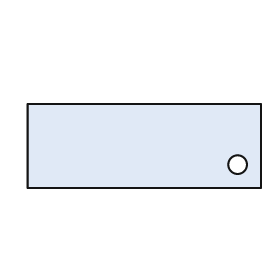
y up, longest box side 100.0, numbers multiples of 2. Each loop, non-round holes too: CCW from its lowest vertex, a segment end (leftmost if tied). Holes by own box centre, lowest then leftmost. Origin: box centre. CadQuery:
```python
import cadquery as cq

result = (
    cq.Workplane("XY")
    .moveTo(-50.0, -18.0)
    .lineTo(50.0, -18.0)
    .lineTo(50.0, 18.0)
    .lineTo(-50.0, 18.0)
    .close()
    .moveTo(40.0, -8.0)
    .circle(4.0)
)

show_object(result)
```